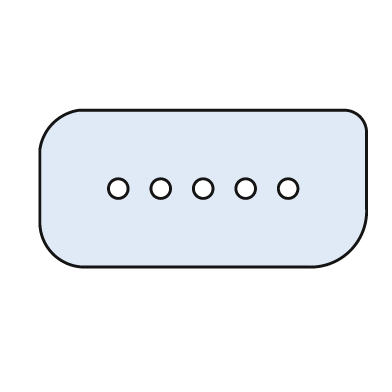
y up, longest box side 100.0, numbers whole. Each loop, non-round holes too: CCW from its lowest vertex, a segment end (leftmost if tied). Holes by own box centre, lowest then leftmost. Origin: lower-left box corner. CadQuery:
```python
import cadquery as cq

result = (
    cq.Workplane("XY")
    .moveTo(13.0, 0.0)
    .lineTo(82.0, 0.0)
    .threePointArc((95.0, 5.0), (100.0, 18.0))
    .lineTo(100.0, 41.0)
    .threePointArc((98.0, 46.0), (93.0, 48.0))
    .lineTo(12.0, 48.0)
    .threePointArc((4.0, 44.0), (0.0, 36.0))
    .lineTo(0.0, 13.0)
    .threePointArc((4.0, 4.0), (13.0, 0.0))
    .close()
    .moveTo(24.0, 24.0)
    .circle(3.0)
    .moveTo(37.0, 24.0)
    .circle(3.0)
    .moveTo(50.0, 24.0)
    .circle(3.0)
    .moveTo(63.0, 24.0)
    .circle(3.0)
    .moveTo(76.0, 24.0)
    .circle(3.0)
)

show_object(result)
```